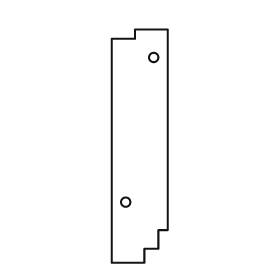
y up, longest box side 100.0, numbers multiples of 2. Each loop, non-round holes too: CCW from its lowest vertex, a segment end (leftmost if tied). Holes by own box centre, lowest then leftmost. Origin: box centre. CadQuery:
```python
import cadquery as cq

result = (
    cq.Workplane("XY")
    .moveTo(-12.0, -50.0)
    .lineTo(2.0, -50.0)
    .lineTo(2.0, -44.0)
    .lineTo(8.0, -44.0)
    .lineTo(8.0, -36.0)
    .lineTo(12.0, -36.0)
    .lineTo(12.0, 50.0)
    .lineTo(-2.0, 50.0)
    .lineTo(-2.0, 46.0)
    .lineTo(-12.0, 46.0)
    .close()
    .moveTo(-6.0, -24.0)
    .circle(2.0)
    .moveTo(6.0, 38.0)
    .circle(2.0)
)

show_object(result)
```